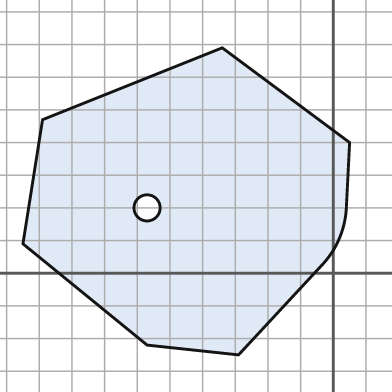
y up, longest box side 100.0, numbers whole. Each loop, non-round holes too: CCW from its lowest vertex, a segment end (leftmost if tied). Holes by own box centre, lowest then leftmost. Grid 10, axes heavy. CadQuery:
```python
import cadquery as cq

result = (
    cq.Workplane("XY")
    .moveTo(-29.0, -25.0)
    .lineTo(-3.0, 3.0)
    .threePointArc((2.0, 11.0), (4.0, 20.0))
    .lineTo(5.0, 40.0)
    .lineTo(-34.0, 69.0)
    .lineTo(-89.0, 47.0)
    .lineTo(-95.0, 9.0)
    .lineTo(-57.0, -22.0)
    .close()
    .moveTo(-57.0, 20.0)
    .circle(4.0)
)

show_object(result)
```